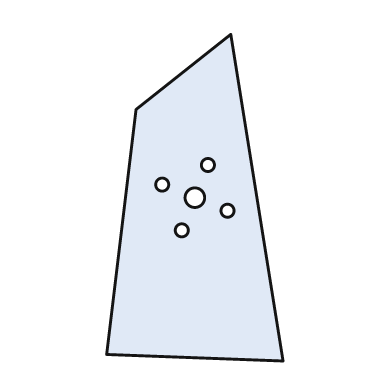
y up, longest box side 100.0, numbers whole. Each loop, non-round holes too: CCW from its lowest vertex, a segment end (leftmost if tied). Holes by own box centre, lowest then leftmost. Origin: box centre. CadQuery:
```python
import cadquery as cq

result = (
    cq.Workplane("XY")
    .moveTo(27.0, -50.0)
    .lineTo(11.0, 50.0)
    .lineTo(-18.0, 27.0)
    .lineTo(-27.0, -48.0)
    .close()
    .moveTo(-4.0, -10.0)
    .circle(2.0)
    .moveTo(10.0, -4.0)
    .circle(2.0)
    .moveTo(0.0, 0.0)
    .circle(3.0)
    .moveTo(-10.0, 4.0)
    .circle(2.0)
    .moveTo(4.0, 10.0)
    .circle(2.0)
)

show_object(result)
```